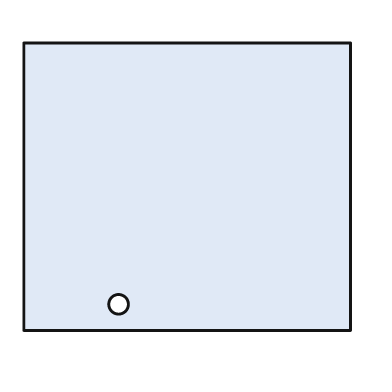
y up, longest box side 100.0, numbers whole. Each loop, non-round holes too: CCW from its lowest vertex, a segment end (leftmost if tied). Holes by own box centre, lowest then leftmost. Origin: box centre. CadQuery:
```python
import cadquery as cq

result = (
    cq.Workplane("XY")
    .moveTo(-50.0, -44.0)
    .lineTo(50.0, -44.0)
    .lineTo(50.0, 44.0)
    .lineTo(-50.0, 44.0)
    .close()
    .moveTo(-21.0, -36.0)
    .circle(3.0)
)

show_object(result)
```